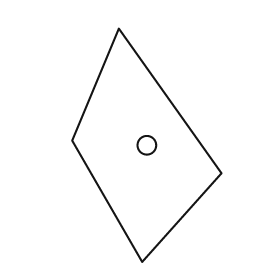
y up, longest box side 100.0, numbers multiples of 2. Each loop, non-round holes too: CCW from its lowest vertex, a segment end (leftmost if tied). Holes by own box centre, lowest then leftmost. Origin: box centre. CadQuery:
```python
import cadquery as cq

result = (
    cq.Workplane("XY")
    .moveTo(-2.0, -50.0)
    .lineTo(32.0, -12.0)
    .lineTo(-12.0, 50.0)
    .lineTo(-32.0, 2.0)
    .close()
    .moveTo(0.0, 0.0)
    .circle(4.0)
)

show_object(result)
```